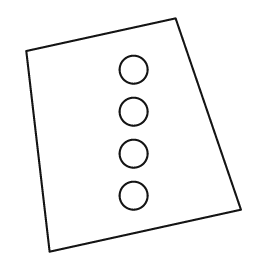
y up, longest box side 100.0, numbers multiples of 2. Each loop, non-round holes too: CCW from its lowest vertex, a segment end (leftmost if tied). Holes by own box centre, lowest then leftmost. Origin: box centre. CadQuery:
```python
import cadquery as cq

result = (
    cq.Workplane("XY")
    .moveTo(-36.0, -50.0)
    .lineTo(46.0, -32.0)
    .lineTo(18.0, 50.0)
    .lineTo(-46.0, 36.0)
    .close()
    .moveTo(0.0, -26.0)
    .circle(6.0)
    .moveTo(0.0, -8.0)
    .circle(6.0)
    .moveTo(0.0, 10.0)
    .circle(6.0)
    .moveTo(0.0, 28.0)
    .circle(6.0)
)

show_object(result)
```